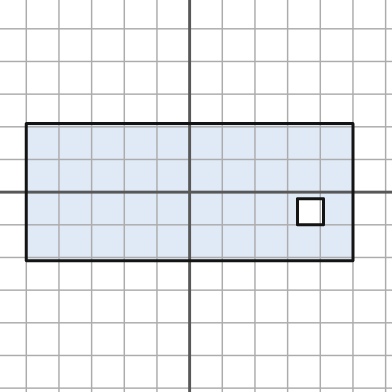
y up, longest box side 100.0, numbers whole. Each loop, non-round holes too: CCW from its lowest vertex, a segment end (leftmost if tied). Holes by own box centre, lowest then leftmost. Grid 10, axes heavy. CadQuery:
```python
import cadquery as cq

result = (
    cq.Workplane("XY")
    .moveTo(-50.0, -21.0)
    .lineTo(50.0, -21.0)
    .lineTo(50.0, 21.0)
    .lineTo(-50.0, 21.0)
    .close()
    .moveTo(33.0, -10.0)
    .lineTo(41.0, -10.0)
    .lineTo(41.0, -2.0)
    .lineTo(33.0, -2.0)
    .close()
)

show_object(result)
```